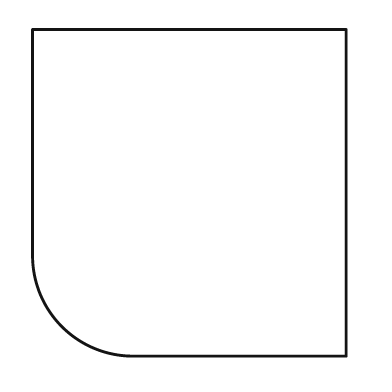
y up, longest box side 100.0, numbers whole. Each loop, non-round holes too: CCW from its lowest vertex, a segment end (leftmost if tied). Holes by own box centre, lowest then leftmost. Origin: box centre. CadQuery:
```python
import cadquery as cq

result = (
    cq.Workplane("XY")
    .moveTo(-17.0, -50.0)
    .lineTo(48.0, -50.0)
    .lineTo(48.0, 50.0)
    .lineTo(-48.0, 50.0)
    .lineTo(-48.0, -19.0)
    .threePointArc((-39.0, -41.0), (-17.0, -50.0))
    .close()
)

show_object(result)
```